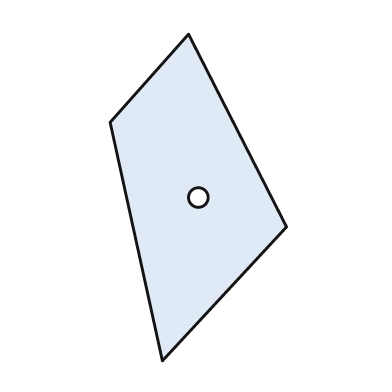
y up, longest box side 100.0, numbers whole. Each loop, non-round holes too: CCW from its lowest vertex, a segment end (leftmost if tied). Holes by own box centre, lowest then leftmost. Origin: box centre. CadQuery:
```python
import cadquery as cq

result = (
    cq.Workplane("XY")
    .moveTo(-11.0, -50.0)
    .lineTo(27.0, -9.0)
    .lineTo(-3.0, 50.0)
    .lineTo(-27.0, 23.0)
    .close()
    .moveTo(0.0, 0.0)
    .circle(3.0)
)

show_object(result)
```